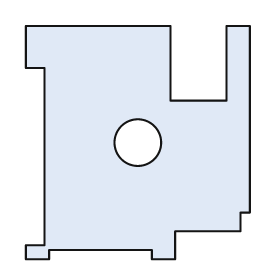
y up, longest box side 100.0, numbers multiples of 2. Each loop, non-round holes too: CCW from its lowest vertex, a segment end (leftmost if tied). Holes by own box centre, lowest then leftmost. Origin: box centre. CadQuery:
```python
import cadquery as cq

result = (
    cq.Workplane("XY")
    .moveTo(-48.0, -50.0)
    .lineTo(-38.0, -50.0)
    .lineTo(-38.0, -46.0)
    .lineTo(6.0, -46.0)
    .lineTo(6.0, -50.0)
    .lineTo(16.0, -50.0)
    .lineTo(16.0, -38.0)
    .lineTo(44.0, -38.0)
    .lineTo(44.0, -30.0)
    .lineTo(48.0, -30.0)
    .lineTo(48.0, 50.0)
    .lineTo(38.0, 50.0)
    .lineTo(38.0, 18.0)
    .lineTo(14.0, 18.0)
    .lineTo(14.0, 50.0)
    .lineTo(-48.0, 50.0)
    .lineTo(-48.0, 32.0)
    .lineTo(-40.0, 32.0)
    .lineTo(-40.0, -44.0)
    .lineTo(-48.0, -44.0)
    .close()
    .moveTo(0.0, 0.0)
    .circle(10.0)
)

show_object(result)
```